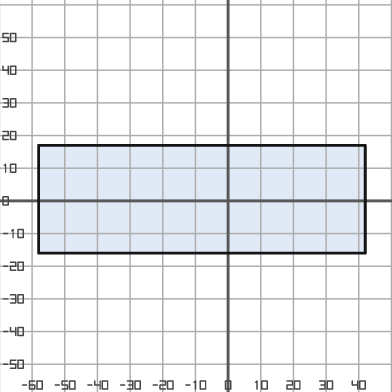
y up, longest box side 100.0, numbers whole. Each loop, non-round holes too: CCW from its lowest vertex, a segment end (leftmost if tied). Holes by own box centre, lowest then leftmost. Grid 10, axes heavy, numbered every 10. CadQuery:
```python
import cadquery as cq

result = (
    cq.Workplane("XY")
    .moveTo(-58.0, -16.0)
    .lineTo(42.0, -16.0)
    .lineTo(42.0, 17.0)
    .lineTo(-58.0, 17.0)
    .close()
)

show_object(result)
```